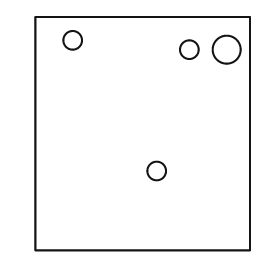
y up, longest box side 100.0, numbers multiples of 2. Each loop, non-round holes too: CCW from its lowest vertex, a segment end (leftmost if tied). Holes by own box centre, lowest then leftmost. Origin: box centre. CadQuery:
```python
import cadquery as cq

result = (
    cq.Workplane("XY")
    .moveTo(-46.0, -50.0)
    .lineTo(46.0, -50.0)
    .lineTo(46.0, 50.0)
    .lineTo(-46.0, 50.0)
    .close()
    .moveTo(6.0, -16.0)
    .circle(4.0)
    .moveTo(20.0, 36.0)
    .circle(4.0)
    .moveTo(36.0, 36.0)
    .circle(6.0)
    .moveTo(-30.0, 40.0)
    .circle(4.0)
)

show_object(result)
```